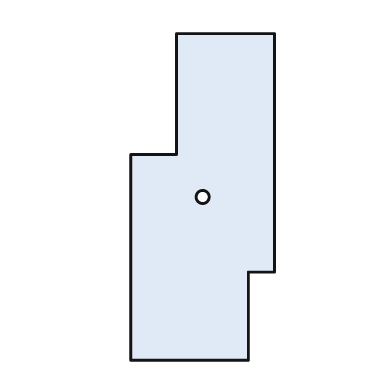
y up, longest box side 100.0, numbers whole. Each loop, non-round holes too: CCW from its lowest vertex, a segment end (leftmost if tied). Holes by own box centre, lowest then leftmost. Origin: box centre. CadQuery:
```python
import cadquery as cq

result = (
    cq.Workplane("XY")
    .moveTo(-22.0, -50.0)
    .lineTo(14.0, -50.0)
    .lineTo(14.0, -23.0)
    .lineTo(22.0, -23.0)
    .lineTo(22.0, 50.0)
    .lineTo(-8.0, 50.0)
    .lineTo(-8.0, 13.0)
    .lineTo(-22.0, 13.0)
    .close()
    .moveTo(0.0, 0.0)
    .circle(2.0)
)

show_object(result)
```